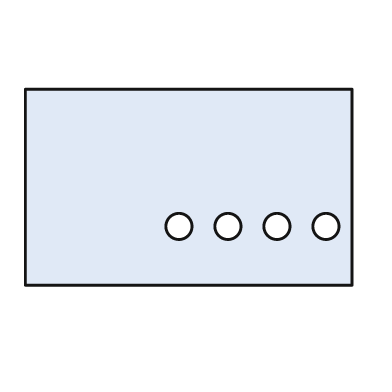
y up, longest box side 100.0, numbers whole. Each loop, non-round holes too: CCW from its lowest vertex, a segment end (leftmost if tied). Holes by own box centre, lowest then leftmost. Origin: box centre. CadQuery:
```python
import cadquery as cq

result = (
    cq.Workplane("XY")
    .moveTo(-50.0, -30.0)
    .lineTo(50.0, -30.0)
    .lineTo(50.0, 30.0)
    .lineTo(-50.0, 30.0)
    .close()
    .moveTo(-3.0, -12.0)
    .circle(4.0)
    .moveTo(12.0, -12.0)
    .circle(4.0)
    .moveTo(27.0, -12.0)
    .circle(4.0)
    .moveTo(42.0, -12.0)
    .circle(4.0)
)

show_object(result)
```